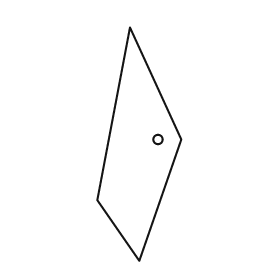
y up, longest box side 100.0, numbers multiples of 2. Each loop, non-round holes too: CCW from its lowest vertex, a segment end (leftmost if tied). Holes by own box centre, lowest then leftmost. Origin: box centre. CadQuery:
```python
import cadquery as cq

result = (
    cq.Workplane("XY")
    .moveTo(0.0, -50.0)
    .lineTo(18.0, 2.0)
    .lineTo(-4.0, 50.0)
    .lineTo(-18.0, -24.0)
    .close()
    .moveTo(8.0, 2.0)
    .circle(2.0)
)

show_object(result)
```